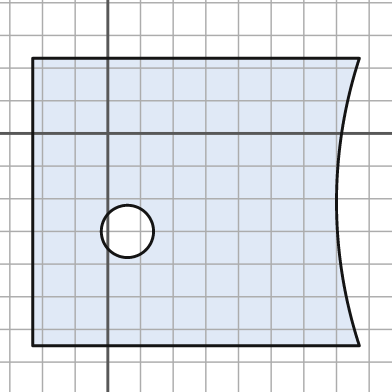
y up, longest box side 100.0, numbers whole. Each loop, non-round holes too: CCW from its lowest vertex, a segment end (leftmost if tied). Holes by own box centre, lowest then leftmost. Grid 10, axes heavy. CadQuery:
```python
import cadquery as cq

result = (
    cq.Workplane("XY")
    .moveTo(-23.0, -65.0)
    .lineTo(77.0, -65.0)
    .threePointArc((70.0, -21.0), (77.0, 23.0))
    .lineTo(-23.0, 23.0)
    .close()
    .moveTo(6.0, -30.0)
    .circle(8.0)
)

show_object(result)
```